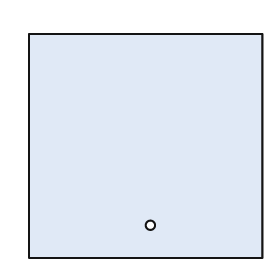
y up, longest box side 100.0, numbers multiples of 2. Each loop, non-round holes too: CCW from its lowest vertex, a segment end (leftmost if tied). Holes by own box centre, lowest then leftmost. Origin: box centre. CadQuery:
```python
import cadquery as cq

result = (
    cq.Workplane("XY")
    .moveTo(-50.0, -48.0)
    .lineTo(50.0, -48.0)
    .lineTo(50.0, 48.0)
    .lineTo(-50.0, 48.0)
    .close()
    .moveTo(2.0, -34.0)
    .circle(2.0)
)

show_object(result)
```